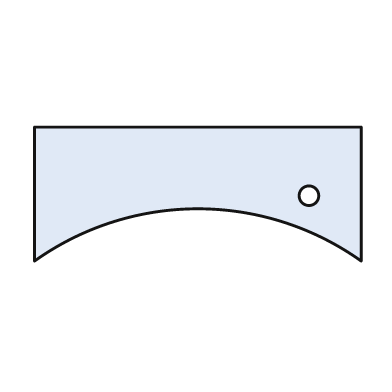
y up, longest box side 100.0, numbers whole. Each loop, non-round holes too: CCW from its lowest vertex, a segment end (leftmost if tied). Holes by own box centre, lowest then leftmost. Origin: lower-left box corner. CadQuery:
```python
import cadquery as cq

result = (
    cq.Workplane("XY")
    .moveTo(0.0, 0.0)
    .threePointArc((50.0, 16.0), (100.0, 0.0))
    .lineTo(100.0, 41.0)
    .lineTo(0.0, 41.0)
    .close()
    .moveTo(84.0, 20.0)
    .circle(3.0)
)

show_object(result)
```